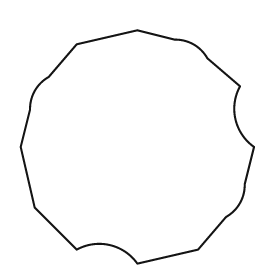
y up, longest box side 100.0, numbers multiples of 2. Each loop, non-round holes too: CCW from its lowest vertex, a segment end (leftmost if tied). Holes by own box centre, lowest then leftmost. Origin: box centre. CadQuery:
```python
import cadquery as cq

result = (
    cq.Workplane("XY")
    .moveTo(0.0, -50.0)
    .lineTo(26.0, -44.0)
    .lineTo(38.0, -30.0)
    .threePointArc((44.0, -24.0), (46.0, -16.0))
    .lineTo(50.0, 0.0)
    .threePointArc((42.0, 12.0), (44.0, 26.0))
    .lineTo(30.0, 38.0)
    .threePointArc((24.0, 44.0), (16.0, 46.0))
    .lineTo(0.0, 50.0)
    .lineTo(-26.0, 44.0)
    .lineTo(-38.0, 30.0)
    .threePointArc((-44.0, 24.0), (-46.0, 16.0))
    .lineTo(-50.0, 0.0)
    .lineTo(-44.0, -26.0)
    .lineTo(-26.0, -44.0)
    .threePointArc((-12.0, -42.0), (0.0, -50.0))
    .close()
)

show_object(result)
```